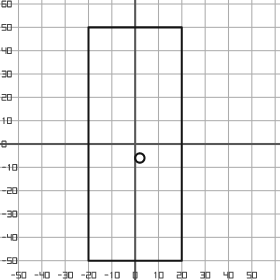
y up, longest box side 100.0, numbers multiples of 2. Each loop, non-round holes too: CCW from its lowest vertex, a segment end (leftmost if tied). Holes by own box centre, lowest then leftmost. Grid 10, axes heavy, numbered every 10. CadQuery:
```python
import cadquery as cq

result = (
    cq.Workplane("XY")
    .moveTo(-20.0, -50.0)
    .lineTo(20.0, -50.0)
    .lineTo(20.0, 50.0)
    .lineTo(-20.0, 50.0)
    .close()
    .moveTo(2.0, -6.0)
    .circle(2.0)
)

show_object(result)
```